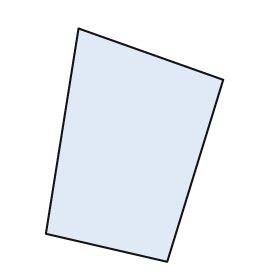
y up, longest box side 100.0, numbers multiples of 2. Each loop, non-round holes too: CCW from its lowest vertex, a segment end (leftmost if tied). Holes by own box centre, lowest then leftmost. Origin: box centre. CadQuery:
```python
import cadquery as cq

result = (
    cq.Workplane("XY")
    .moveTo(14.0, -50.0)
    .lineTo(38.0, 28.0)
    .lineTo(-24.0, 50.0)
    .lineTo(-38.0, -38.0)
    .close()
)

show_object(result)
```